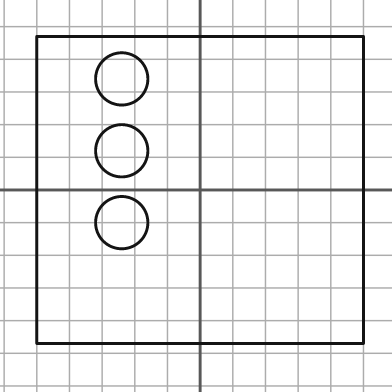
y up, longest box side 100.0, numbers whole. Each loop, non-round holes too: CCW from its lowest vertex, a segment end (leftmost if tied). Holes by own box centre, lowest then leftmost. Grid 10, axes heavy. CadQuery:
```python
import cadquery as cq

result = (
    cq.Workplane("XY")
    .moveTo(-50.0, -47.0)
    .lineTo(50.0, -47.0)
    .lineTo(50.0, 47.0)
    .lineTo(-50.0, 47.0)
    .close()
    .moveTo(-24.0, -10.0)
    .circle(8.0)
    .moveTo(-24.0, 12.0)
    .circle(8.0)
    .moveTo(-24.0, 34.0)
    .circle(8.0)
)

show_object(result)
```